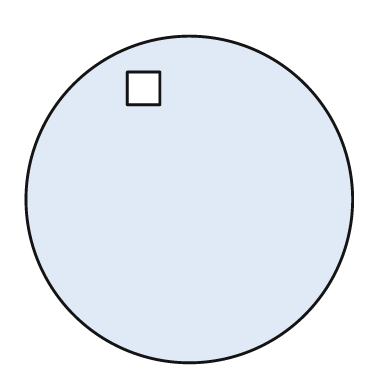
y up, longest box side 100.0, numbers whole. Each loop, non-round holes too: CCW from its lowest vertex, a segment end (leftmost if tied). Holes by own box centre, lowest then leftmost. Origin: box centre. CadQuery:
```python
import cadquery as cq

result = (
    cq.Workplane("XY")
    .moveTo(0.0, 0.0)
    .circle(50.0)
    .moveTo(-19.0, 29.0)
    .lineTo(-9.0, 29.0)
    .lineTo(-9.0, 39.0)
    .lineTo(-19.0, 39.0)
    .close()
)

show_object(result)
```